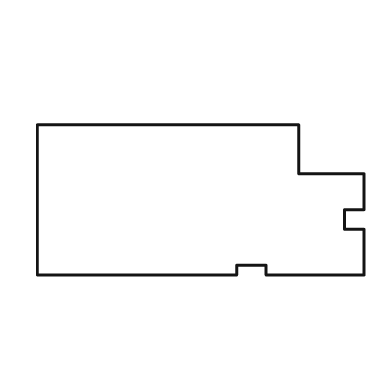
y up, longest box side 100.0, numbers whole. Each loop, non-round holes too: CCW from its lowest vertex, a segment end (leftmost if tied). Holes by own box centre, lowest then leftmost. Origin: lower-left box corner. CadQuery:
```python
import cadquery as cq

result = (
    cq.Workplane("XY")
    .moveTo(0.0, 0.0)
    .lineTo(61.0, 0.0)
    .lineTo(61.0, 3.0)
    .lineTo(70.0, 3.0)
    .lineTo(70.0, 0.0)
    .lineTo(100.0, 0.0)
    .lineTo(100.0, 14.0)
    .lineTo(94.0, 14.0)
    .lineTo(94.0, 20.0)
    .lineTo(100.0, 20.0)
    .lineTo(100.0, 31.0)
    .lineTo(80.0, 31.0)
    .lineTo(80.0, 46.0)
    .lineTo(0.0, 46.0)
    .close()
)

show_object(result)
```